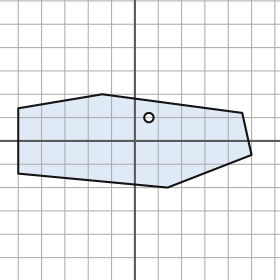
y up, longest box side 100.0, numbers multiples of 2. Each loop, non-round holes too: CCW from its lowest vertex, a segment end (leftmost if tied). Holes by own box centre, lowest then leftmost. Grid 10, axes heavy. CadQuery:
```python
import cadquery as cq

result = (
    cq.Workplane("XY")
    .moveTo(14.0, -20.0)
    .lineTo(50.0, -6.0)
    .lineTo(46.0, 12.0)
    .lineTo(-14.0, 20.0)
    .lineTo(-50.0, 14.0)
    .lineTo(-50.0, -14.0)
    .close()
    .moveTo(6.0, 10.0)
    .circle(2.0)
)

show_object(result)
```